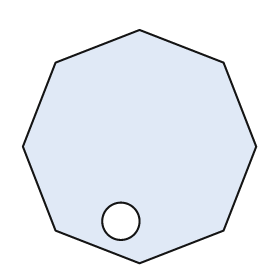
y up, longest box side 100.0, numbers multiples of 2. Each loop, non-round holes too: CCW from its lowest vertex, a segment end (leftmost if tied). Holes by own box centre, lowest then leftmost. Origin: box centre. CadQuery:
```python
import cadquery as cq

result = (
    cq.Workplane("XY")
    .moveTo(0.0, -50.0)
    .lineTo(36.0, -36.0)
    .lineTo(50.0, 0.0)
    .lineTo(36.0, 36.0)
    .lineTo(0.0, 50.0)
    .lineTo(-36.0, 36.0)
    .lineTo(-50.0, 0.0)
    .lineTo(-36.0, -36.0)
    .close()
    .moveTo(-8.0, -32.0)
    .circle(8.0)
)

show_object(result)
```